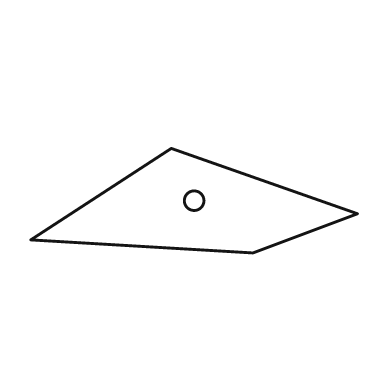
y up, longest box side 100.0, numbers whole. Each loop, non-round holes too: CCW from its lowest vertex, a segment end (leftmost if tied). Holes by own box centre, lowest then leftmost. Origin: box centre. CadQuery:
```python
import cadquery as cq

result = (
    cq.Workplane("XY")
    .moveTo(18.0, -16.0)
    .lineTo(50.0, -4.0)
    .lineTo(-7.0, 16.0)
    .lineTo(-50.0, -12.0)
    .close()
    .moveTo(0.0, 0.0)
    .circle(3.0)
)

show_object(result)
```